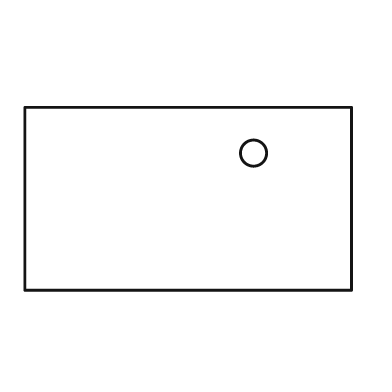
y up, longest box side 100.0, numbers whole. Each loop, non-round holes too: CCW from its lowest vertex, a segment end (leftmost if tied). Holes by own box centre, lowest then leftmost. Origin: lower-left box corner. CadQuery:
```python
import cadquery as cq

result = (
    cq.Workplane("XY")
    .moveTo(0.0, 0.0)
    .lineTo(100.0, 0.0)
    .lineTo(100.0, 56.0)
    .lineTo(0.0, 56.0)
    .close()
    .moveTo(70.0, 42.0)
    .circle(4.0)
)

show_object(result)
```